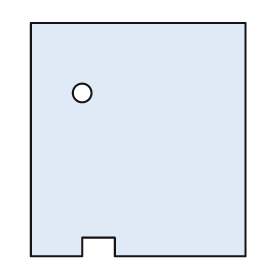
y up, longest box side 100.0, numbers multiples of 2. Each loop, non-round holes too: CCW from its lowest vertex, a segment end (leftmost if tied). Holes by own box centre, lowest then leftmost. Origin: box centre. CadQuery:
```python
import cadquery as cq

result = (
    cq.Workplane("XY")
    .moveTo(-46.0, -50.0)
    .lineTo(-24.0, -50.0)
    .lineTo(-24.0, -42.0)
    .lineTo(-10.0, -42.0)
    .lineTo(-10.0, -50.0)
    .lineTo(46.0, -50.0)
    .lineTo(46.0, 50.0)
    .lineTo(-46.0, 50.0)
    .close()
    .moveTo(-24.0, 20.0)
    .circle(4.0)
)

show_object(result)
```